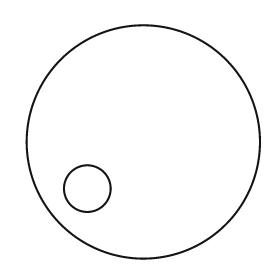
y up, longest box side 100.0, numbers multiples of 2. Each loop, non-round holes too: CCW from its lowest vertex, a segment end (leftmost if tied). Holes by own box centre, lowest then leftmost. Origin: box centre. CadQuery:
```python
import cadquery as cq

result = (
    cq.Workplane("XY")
    .moveTo(0.0, 0.0)
    .circle(50.0)
    .moveTo(-24.0, -20.0)
    .circle(10.0)
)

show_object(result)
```